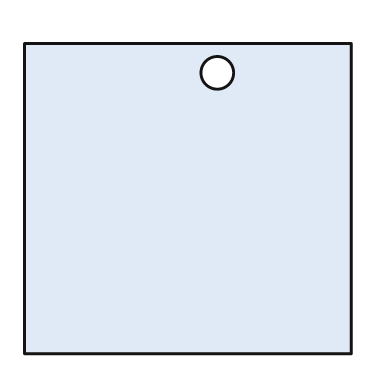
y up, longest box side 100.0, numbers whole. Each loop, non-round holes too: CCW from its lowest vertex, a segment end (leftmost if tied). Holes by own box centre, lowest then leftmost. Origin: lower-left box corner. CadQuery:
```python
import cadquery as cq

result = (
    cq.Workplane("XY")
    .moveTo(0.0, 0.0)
    .lineTo(100.0, 0.0)
    .lineTo(100.0, 95.0)
    .lineTo(0.0, 95.0)
    .close()
    .moveTo(59.0, 86.0)
    .circle(5.0)
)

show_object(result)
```